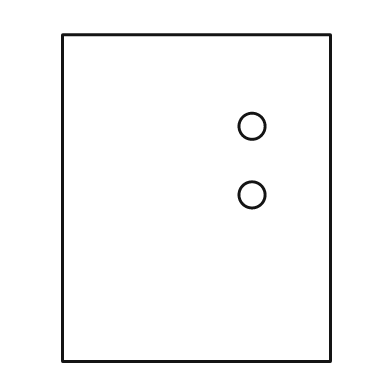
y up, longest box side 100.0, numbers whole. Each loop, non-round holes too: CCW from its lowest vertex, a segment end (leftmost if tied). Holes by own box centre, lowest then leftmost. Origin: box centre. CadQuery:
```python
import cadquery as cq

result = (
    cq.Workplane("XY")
    .moveTo(-41.0, -50.0)
    .lineTo(41.0, -50.0)
    .lineTo(41.0, 50.0)
    .lineTo(-41.0, 50.0)
    .close()
    .moveTo(17.0, 1.0)
    .circle(4.0)
    .moveTo(17.0, 22.0)
    .circle(4.0)
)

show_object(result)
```